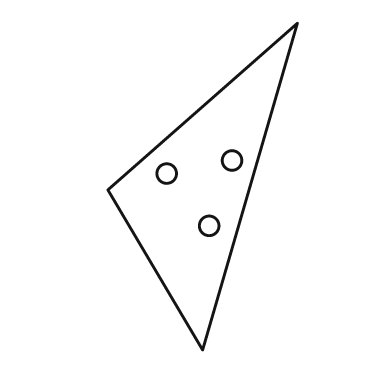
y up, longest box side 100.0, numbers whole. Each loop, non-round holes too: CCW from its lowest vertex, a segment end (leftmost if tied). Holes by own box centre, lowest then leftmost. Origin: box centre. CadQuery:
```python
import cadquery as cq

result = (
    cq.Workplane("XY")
    .moveTo(0.0, -50.0)
    .lineTo(29.0, 50.0)
    .lineTo(-29.0, -1.0)
    .close()
    .moveTo(2.0, -12.0)
    .circle(3.0)
    .moveTo(-11.0, 4.0)
    .circle(3.0)
    .moveTo(9.0, 8.0)
    .circle(3.0)
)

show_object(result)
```